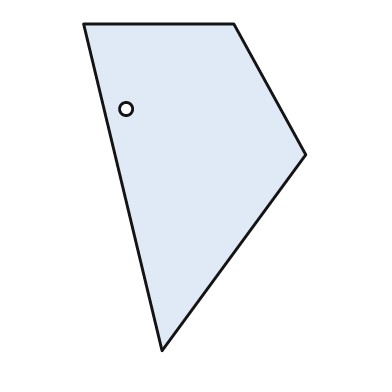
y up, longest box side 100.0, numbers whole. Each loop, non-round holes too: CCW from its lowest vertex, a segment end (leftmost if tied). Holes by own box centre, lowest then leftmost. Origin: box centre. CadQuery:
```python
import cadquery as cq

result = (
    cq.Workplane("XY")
    .moveTo(-10.0, -50.0)
    .lineTo(34.0, 10.0)
    .lineTo(12.0, 50.0)
    .lineTo(-34.0, 50.0)
    .close()
    .moveTo(-21.0, 24.0)
    .circle(2.0)
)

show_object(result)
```